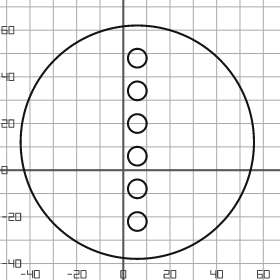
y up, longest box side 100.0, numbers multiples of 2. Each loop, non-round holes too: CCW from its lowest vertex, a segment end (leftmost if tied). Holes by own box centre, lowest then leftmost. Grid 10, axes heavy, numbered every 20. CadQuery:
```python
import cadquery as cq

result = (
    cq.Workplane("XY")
    .moveTo(6.0, 12.0)
    .circle(50.0)
    .moveTo(6.0, -22.0)
    .circle(4.0)
    .moveTo(6.0, -8.0)
    .circle(4.0)
    .moveTo(6.0, 6.0)
    .circle(4.0)
    .moveTo(6.0, 20.0)
    .circle(4.0)
    .moveTo(6.0, 34.0)
    .circle(4.0)
    .moveTo(6.0, 48.0)
    .circle(4.0)
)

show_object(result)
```